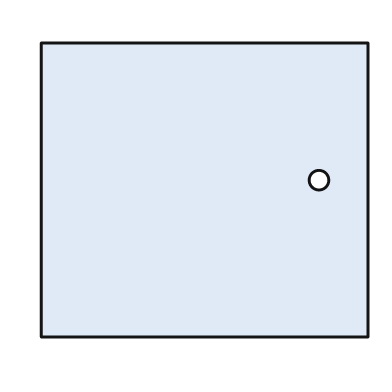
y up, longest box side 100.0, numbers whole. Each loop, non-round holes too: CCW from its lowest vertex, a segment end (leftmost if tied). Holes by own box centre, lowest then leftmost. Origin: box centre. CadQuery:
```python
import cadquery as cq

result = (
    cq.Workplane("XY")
    .moveTo(-50.0, -45.0)
    .lineTo(50.0, -45.0)
    .lineTo(50.0, 45.0)
    .lineTo(-50.0, 45.0)
    .close()
    .moveTo(35.0, 3.0)
    .circle(3.0)
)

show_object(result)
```